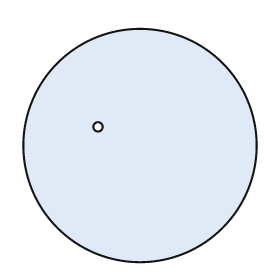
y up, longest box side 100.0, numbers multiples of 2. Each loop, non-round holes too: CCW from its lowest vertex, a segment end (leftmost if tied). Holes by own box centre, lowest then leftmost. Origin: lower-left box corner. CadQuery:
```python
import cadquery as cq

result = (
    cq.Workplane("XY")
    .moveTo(50.0, 50.0)
    .circle(50.0)
    .moveTo(32.0, 58.0)
    .circle(2.0)
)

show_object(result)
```